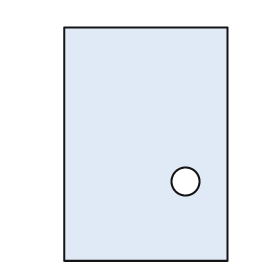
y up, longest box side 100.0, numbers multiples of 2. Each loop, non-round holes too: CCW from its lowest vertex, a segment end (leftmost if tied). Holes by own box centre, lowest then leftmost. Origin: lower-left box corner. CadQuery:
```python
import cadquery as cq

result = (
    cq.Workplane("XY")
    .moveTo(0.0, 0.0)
    .lineTo(70.0, 0.0)
    .lineTo(70.0, 100.0)
    .lineTo(0.0, 100.0)
    .close()
    .moveTo(52.0, 34.0)
    .circle(6.0)
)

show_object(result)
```